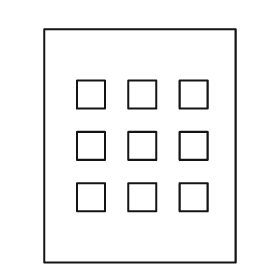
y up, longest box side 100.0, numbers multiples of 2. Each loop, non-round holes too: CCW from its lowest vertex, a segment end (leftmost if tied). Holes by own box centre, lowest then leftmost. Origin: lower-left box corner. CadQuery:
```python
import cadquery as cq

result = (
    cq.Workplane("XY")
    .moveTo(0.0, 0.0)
    .lineTo(82.0, 0.0)
    .lineTo(82.0, 100.0)
    .lineTo(0.0, 100.0)
    .close()
    .moveTo(14.0, 22.0)
    .lineTo(26.0, 22.0)
    .lineTo(26.0, 34.0)
    .lineTo(14.0, 34.0)
    .close()
    .moveTo(36.0, 22.0)
    .lineTo(48.0, 22.0)
    .lineTo(48.0, 34.0)
    .lineTo(36.0, 34.0)
    .close()
    .moveTo(58.0, 22.0)
    .lineTo(70.0, 22.0)
    .lineTo(70.0, 34.0)
    .lineTo(58.0, 34.0)
    .close()
    .moveTo(14.0, 44.0)
    .lineTo(26.0, 44.0)
    .lineTo(26.0, 56.0)
    .lineTo(14.0, 56.0)
    .close()
    .moveTo(36.0, 44.0)
    .lineTo(48.0, 44.0)
    .lineTo(48.0, 56.0)
    .lineTo(36.0, 56.0)
    .close()
    .moveTo(58.0, 44.0)
    .lineTo(70.0, 44.0)
    .lineTo(70.0, 56.0)
    .lineTo(58.0, 56.0)
    .close()
    .moveTo(14.0, 66.0)
    .lineTo(26.0, 66.0)
    .lineTo(26.0, 78.0)
    .lineTo(14.0, 78.0)
    .close()
    .moveTo(36.0, 66.0)
    .lineTo(48.0, 66.0)
    .lineTo(48.0, 78.0)
    .lineTo(36.0, 78.0)
    .close()
    .moveTo(58.0, 66.0)
    .lineTo(70.0, 66.0)
    .lineTo(70.0, 78.0)
    .lineTo(58.0, 78.0)
    .close()
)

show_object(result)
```